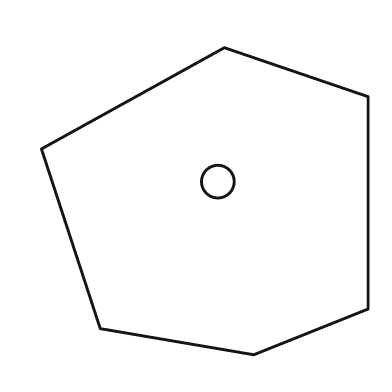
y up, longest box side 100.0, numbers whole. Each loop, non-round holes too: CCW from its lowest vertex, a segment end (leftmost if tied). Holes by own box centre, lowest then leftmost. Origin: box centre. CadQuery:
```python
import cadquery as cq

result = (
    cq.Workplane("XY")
    .moveTo(15.0, -47.0)
    .lineTo(50.0, -33.0)
    .lineTo(50.0, 32.0)
    .lineTo(6.0, 47.0)
    .lineTo(-50.0, 16.0)
    .lineTo(-32.0, -39.0)
    .close()
    .moveTo(4.0, 6.0)
    .circle(5.0)
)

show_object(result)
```